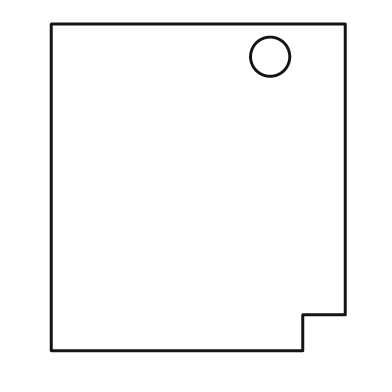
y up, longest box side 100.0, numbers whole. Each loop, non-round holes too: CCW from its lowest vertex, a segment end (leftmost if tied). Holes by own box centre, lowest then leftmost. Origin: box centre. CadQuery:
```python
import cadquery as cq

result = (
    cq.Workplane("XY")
    .moveTo(-45.0, -50.0)
    .lineTo(32.0, -50.0)
    .lineTo(32.0, -39.0)
    .lineTo(45.0, -39.0)
    .lineTo(45.0, 50.0)
    .lineTo(-45.0, 50.0)
    .close()
    .moveTo(22.0, 40.0)
    .circle(6.0)
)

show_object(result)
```